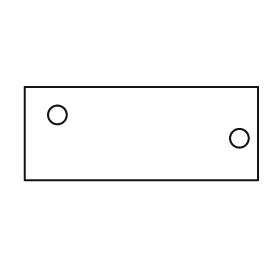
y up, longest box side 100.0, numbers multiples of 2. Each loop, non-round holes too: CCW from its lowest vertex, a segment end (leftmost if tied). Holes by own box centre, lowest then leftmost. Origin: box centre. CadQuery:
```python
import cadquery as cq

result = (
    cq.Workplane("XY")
    .moveTo(-50.0, -20.0)
    .lineTo(50.0, -20.0)
    .lineTo(50.0, 20.0)
    .lineTo(-50.0, 20.0)
    .close()
    .moveTo(42.0, -2.0)
    .circle(4.0)
    .moveTo(-36.0, 8.0)
    .circle(4.0)
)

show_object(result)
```